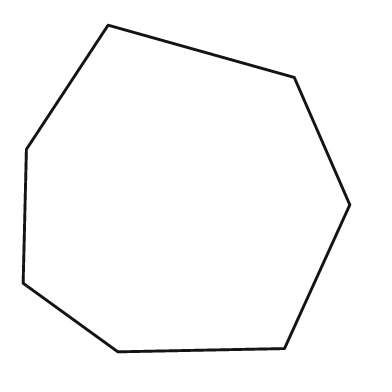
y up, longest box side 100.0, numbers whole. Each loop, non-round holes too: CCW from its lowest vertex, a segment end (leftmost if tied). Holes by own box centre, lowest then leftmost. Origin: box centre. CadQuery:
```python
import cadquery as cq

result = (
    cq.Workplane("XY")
    .moveTo(-21.0, -50.0)
    .lineTo(30.0, -49.0)
    .lineTo(50.0, -5.0)
    .lineTo(33.0, 34.0)
    .lineTo(-24.0, 50.0)
    .lineTo(-49.0, 12.0)
    .lineTo(-50.0, -29.0)
    .close()
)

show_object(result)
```